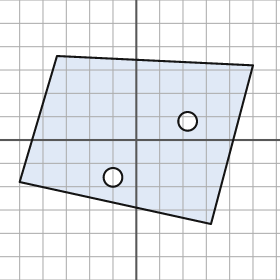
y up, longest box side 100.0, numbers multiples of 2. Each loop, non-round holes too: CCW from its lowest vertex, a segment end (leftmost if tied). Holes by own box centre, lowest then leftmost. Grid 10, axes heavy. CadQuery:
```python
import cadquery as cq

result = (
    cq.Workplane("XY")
    .moveTo(32.0, -36.0)
    .lineTo(50.0, 32.0)
    .lineTo(-34.0, 36.0)
    .lineTo(-50.0, -18.0)
    .close()
    .moveTo(-10.0, -16.0)
    .circle(4.0)
    .moveTo(22.0, 8.0)
    .circle(4.0)
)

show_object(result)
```